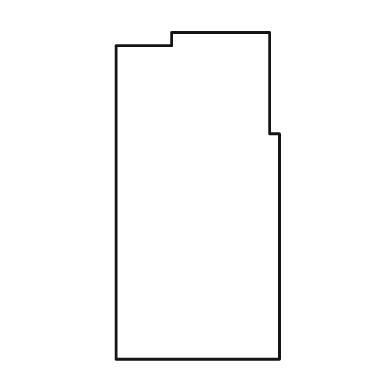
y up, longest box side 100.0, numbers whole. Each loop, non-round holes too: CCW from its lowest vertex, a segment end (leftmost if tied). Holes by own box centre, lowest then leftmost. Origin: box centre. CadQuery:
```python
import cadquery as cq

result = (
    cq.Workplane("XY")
    .moveTo(-25.0, -50.0)
    .lineTo(25.0, -50.0)
    .lineTo(25.0, 19.0)
    .lineTo(22.0, 19.0)
    .lineTo(22.0, 50.0)
    .lineTo(-8.0, 50.0)
    .lineTo(-8.0, 46.0)
    .lineTo(-25.0, 46.0)
    .close()
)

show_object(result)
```